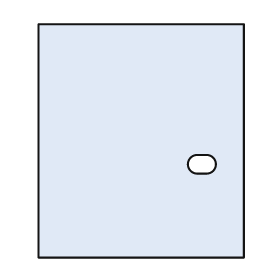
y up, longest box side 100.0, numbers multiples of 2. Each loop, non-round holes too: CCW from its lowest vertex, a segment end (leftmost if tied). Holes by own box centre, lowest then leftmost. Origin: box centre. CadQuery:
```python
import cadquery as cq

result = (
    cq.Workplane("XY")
    .moveTo(-44.0, -50.0)
    .lineTo(44.0, -50.0)
    .lineTo(44.0, 50.0)
    .lineTo(-44.0, 50.0)
    .close()
    .moveTo(24.0, -14.0)
    .lineTo(28.0, -14.0)
    .threePointArc((32.0, -10.0), (28.0, -6.0))
    .lineTo(24.0, -6.0)
    .threePointArc((20.0, -10.0), (24.0, -14.0))
    .close()
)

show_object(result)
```